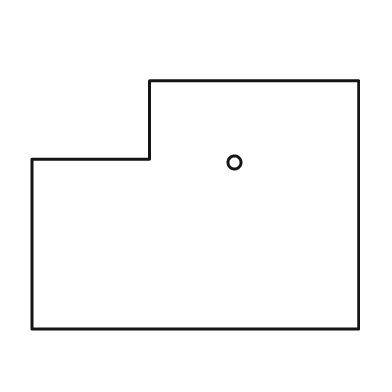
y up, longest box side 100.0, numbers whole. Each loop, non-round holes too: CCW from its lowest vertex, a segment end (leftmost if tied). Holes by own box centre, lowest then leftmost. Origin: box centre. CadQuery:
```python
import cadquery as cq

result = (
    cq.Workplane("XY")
    .moveTo(-50.0, -38.0)
    .lineTo(50.0, -38.0)
    .lineTo(50.0, 38.0)
    .lineTo(-14.0, 38.0)
    .lineTo(-14.0, 14.0)
    .lineTo(-50.0, 14.0)
    .close()
    .moveTo(12.0, 13.0)
    .circle(2.0)
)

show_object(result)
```